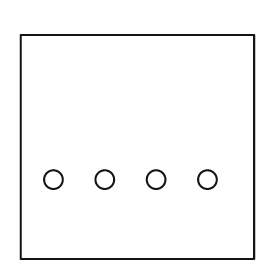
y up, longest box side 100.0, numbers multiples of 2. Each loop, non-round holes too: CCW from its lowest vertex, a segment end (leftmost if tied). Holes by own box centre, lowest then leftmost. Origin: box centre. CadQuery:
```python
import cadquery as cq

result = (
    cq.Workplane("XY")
    .moveTo(-50.0, -48.0)
    .lineTo(50.0, -48.0)
    .lineTo(50.0, 48.0)
    .lineTo(-50.0, 48.0)
    .close()
    .moveTo(-36.0, -14.0)
    .circle(4.0)
    .moveTo(-14.0, -14.0)
    .circle(4.0)
    .moveTo(8.0, -14.0)
    .circle(4.0)
    .moveTo(30.0, -14.0)
    .circle(4.0)
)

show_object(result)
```